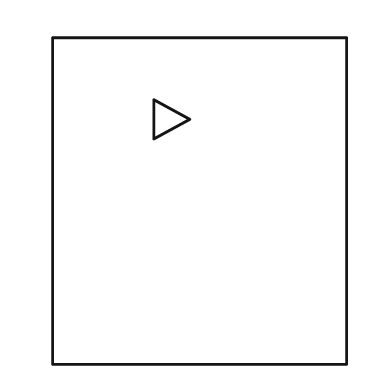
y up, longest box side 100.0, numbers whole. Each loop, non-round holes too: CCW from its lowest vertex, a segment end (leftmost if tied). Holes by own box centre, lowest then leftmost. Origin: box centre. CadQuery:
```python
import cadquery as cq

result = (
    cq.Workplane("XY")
    .moveTo(-45.0, -50.0)
    .lineTo(45.0, -50.0)
    .lineTo(45.0, 50.0)
    .lineTo(-45.0, 50.0)
    .close()
    .moveTo(-14.0, 19.0)
    .lineTo(-3.0, 25.0)
    .lineTo(-14.0, 31.0)
    .close()
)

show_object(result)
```